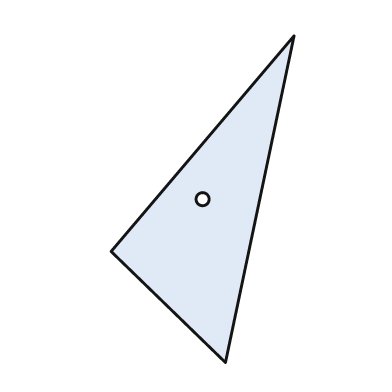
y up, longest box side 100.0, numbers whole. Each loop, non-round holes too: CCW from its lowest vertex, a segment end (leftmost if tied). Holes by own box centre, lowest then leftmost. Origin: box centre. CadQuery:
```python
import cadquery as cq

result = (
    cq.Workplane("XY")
    .moveTo(7.0, -50.0)
    .lineTo(28.0, 50.0)
    .lineTo(-28.0, -16.0)
    .close()
    .moveTo(0.0, 0.0)
    .circle(2.0)
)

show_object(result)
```